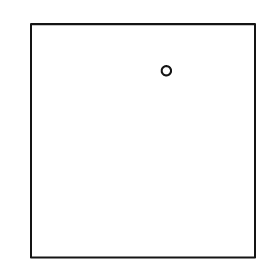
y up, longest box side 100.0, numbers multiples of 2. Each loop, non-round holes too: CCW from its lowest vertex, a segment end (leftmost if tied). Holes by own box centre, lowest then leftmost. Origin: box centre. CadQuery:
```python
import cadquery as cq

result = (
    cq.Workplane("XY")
    .moveTo(-48.0, -50.0)
    .lineTo(48.0, -50.0)
    .lineTo(48.0, 50.0)
    .lineTo(-48.0, 50.0)
    .close()
    .moveTo(10.0, 30.0)
    .circle(2.0)
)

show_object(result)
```